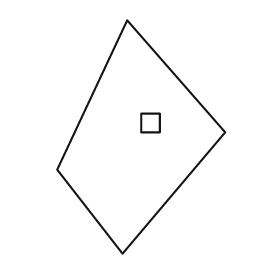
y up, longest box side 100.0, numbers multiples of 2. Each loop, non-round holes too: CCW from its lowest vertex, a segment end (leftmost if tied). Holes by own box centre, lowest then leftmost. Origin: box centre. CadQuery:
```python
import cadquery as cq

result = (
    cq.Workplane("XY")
    .moveTo(-8.0, -50.0)
    .lineTo(36.0, 2.0)
    .lineTo(-6.0, 50.0)
    .lineTo(-36.0, -14.0)
    .close()
    .moveTo(0.0, 2.0)
    .lineTo(8.0, 2.0)
    .lineTo(8.0, 10.0)
    .lineTo(0.0, 10.0)
    .close()
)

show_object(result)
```